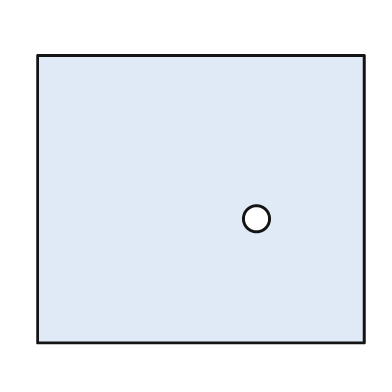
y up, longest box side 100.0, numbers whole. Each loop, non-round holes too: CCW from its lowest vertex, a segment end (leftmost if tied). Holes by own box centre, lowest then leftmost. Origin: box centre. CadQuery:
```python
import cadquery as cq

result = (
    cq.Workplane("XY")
    .moveTo(-50.0, -44.0)
    .lineTo(50.0, -44.0)
    .lineTo(50.0, 44.0)
    .lineTo(-50.0, 44.0)
    .close()
    .moveTo(17.0, -6.0)
    .circle(4.0)
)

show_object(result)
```